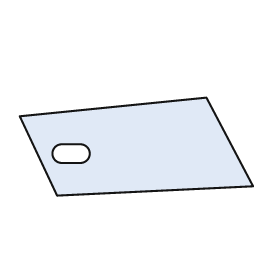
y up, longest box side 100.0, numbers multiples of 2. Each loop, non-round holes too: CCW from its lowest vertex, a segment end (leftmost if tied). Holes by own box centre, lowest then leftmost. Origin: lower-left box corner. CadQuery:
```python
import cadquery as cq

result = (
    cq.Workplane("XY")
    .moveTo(16.0, 0.0)
    .lineTo(100.0, 4.0)
    .lineTo(80.0, 42.0)
    .lineTo(0.0, 34.0)
    .close()
    .moveTo(18.0, 14.0)
    .lineTo(26.0, 14.0)
    .threePointArc((30.0, 18.0), (26.0, 22.0))
    .lineTo(18.0, 22.0)
    .threePointArc((14.0, 18.0), (18.0, 14.0))
    .close()
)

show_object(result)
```